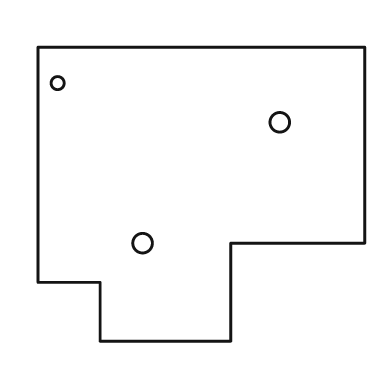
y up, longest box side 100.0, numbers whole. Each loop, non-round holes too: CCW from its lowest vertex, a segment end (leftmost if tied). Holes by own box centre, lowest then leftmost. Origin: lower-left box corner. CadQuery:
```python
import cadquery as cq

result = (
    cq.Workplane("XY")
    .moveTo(19.0, 0.0)
    .lineTo(59.0, 0.0)
    .lineTo(59.0, 30.0)
    .lineTo(100.0, 30.0)
    .lineTo(100.0, 90.0)
    .lineTo(0.0, 90.0)
    .lineTo(0.0, 18.0)
    .lineTo(19.0, 18.0)
    .close()
    .moveTo(32.0, 30.0)
    .circle(3.0)
    .moveTo(74.0, 67.0)
    .circle(3.0)
    .moveTo(6.0, 79.0)
    .circle(2.0)
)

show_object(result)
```